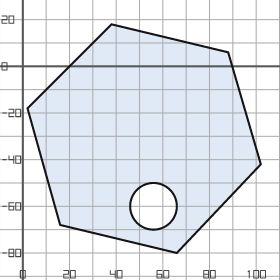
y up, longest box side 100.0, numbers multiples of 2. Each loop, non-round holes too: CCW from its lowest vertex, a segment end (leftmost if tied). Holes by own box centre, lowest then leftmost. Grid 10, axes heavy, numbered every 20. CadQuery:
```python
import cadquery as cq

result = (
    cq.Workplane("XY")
    .moveTo(66.0, -80.0)
    .lineTo(102.0, -42.0)
    .lineTo(88.0, 6.0)
    .lineTo(38.0, 18.0)
    .lineTo(2.0, -18.0)
    .lineTo(16.0, -68.0)
    .close()
    .moveTo(56.0, -60.0)
    .circle(10.0)
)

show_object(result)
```